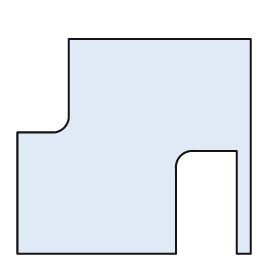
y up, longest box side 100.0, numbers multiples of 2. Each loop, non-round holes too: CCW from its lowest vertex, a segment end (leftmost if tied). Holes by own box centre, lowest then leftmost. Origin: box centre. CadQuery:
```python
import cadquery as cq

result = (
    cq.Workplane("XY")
    .moveTo(-50.0, -46.0)
    .lineTo(18.0, -46.0)
    .lineTo(18.0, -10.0)
    .threePointArc((20.0, -4.0), (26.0, -2.0))
    .lineTo(44.0, -2.0)
    .lineTo(44.0, -46.0)
    .lineTo(50.0, -46.0)
    .lineTo(50.0, 46.0)
    .lineTo(-28.0, 46.0)
    .lineTo(-28.0, 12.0)
    .threePointArc((-30.0, 8.0), (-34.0, 6.0))
    .lineTo(-50.0, 6.0)
    .close()
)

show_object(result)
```